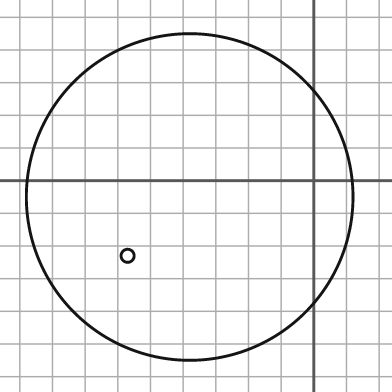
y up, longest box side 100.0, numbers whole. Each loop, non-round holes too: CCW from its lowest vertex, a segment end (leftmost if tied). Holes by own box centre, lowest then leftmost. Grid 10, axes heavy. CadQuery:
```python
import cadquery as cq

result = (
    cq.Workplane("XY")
    .moveTo(-38.0, -5.0)
    .circle(50.0)
    .moveTo(-57.0, -23.0)
    .circle(2.0)
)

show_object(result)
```